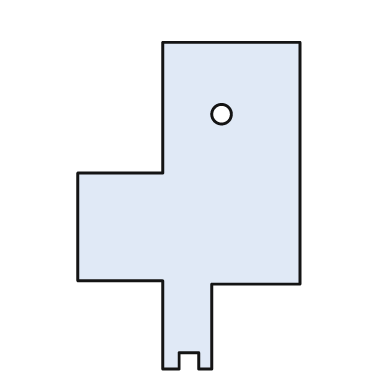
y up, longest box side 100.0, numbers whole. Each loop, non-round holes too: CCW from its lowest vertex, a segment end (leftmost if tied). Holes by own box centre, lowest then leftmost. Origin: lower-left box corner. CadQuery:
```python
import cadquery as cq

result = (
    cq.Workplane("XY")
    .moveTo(26.0, 0.0)
    .lineTo(31.0, 0.0)
    .lineTo(31.0, 5.0)
    .lineTo(37.0, 5.0)
    .lineTo(37.0, 0.0)
    .lineTo(41.0, 0.0)
    .lineTo(41.0, 26.0)
    .lineTo(68.0, 26.0)
    .lineTo(68.0, 100.0)
    .lineTo(26.0, 100.0)
    .lineTo(26.0, 60.0)
    .lineTo(0.0, 60.0)
    .lineTo(0.0, 27.0)
    .lineTo(26.0, 27.0)
    .close()
    .moveTo(44.0, 78.0)
    .circle(3.0)
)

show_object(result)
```